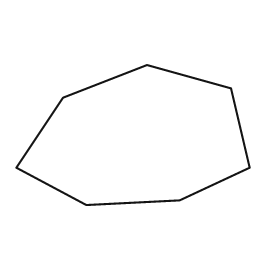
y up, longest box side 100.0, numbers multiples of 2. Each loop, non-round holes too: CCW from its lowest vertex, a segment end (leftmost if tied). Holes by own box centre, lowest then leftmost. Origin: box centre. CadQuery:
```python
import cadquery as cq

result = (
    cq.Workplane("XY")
    .moveTo(-20.0, -30.0)
    .lineTo(20.0, -28.0)
    .lineTo(50.0, -14.0)
    .lineTo(42.0, 20.0)
    .lineTo(6.0, 30.0)
    .lineTo(-30.0, 16.0)
    .lineTo(-50.0, -14.0)
    .close()
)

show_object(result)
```